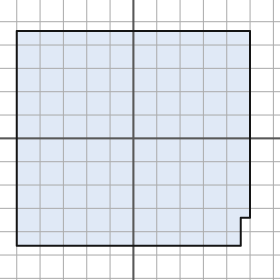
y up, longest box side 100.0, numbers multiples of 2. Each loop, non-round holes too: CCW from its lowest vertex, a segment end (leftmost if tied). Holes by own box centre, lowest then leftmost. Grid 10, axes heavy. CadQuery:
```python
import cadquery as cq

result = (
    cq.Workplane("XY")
    .moveTo(-50.0, -46.0)
    .lineTo(46.0, -46.0)
    .lineTo(46.0, -34.0)
    .lineTo(50.0, -34.0)
    .lineTo(50.0, 46.0)
    .lineTo(-50.0, 46.0)
    .close()
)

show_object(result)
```